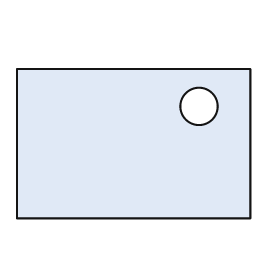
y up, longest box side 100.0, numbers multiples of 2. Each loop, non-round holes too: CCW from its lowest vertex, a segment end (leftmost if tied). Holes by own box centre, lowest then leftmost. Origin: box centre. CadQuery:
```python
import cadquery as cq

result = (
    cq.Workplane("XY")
    .moveTo(-50.0, -32.0)
    .lineTo(50.0, -32.0)
    .lineTo(50.0, 32.0)
    .lineTo(-50.0, 32.0)
    .close()
    .moveTo(28.0, 16.0)
    .circle(8.0)
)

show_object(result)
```